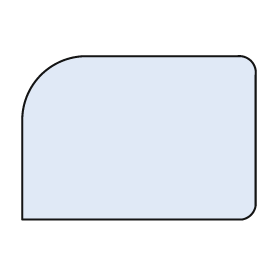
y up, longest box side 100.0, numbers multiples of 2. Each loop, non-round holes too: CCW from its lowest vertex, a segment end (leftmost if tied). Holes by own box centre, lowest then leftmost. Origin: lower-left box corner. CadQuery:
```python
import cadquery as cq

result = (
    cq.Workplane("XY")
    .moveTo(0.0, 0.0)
    .lineTo(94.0, 0.0)
    .threePointArc((98.0, 2.0), (100.0, 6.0))
    .lineTo(100.0, 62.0)
    .threePointArc((98.0, 68.0), (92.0, 70.0))
    .lineTo(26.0, 70.0)
    .threePointArc((8.0, 62.0), (0.0, 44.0))
    .close()
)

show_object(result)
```